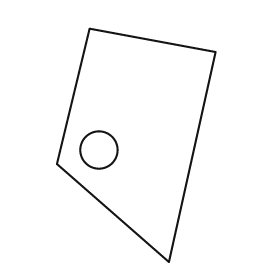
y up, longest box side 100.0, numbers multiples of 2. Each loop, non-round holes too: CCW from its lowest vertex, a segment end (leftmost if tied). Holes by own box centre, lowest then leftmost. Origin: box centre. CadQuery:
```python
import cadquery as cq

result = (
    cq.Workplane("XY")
    .moveTo(14.0, -50.0)
    .lineTo(34.0, 40.0)
    .lineTo(-20.0, 50.0)
    .lineTo(-34.0, -8.0)
    .close()
    .moveTo(-16.0, -2.0)
    .circle(8.0)
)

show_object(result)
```